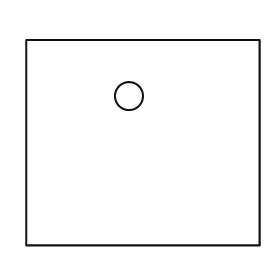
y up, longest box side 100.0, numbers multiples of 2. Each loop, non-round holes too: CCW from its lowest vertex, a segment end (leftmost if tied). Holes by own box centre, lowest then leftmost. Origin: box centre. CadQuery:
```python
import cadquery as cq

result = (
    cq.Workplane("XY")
    .moveTo(-50.0, -44.0)
    .lineTo(50.0, -44.0)
    .lineTo(50.0, 44.0)
    .lineTo(-50.0, 44.0)
    .close()
    .moveTo(-6.0, 20.0)
    .circle(6.0)
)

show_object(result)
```